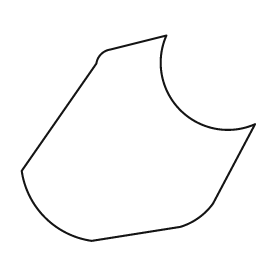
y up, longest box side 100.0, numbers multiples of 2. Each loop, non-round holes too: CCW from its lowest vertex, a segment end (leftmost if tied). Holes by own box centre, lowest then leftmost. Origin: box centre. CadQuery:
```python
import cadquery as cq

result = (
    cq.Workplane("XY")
    .moveTo(-20.0, -44.0)
    .lineTo(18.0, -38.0)
    .threePointArc((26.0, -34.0), (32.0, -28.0))
    .lineTo(50.0, 6.0)
    .threePointArc((18.0, 12.0), (12.0, 44.0))
    .lineTo(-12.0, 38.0)
    .threePointArc((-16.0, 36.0), (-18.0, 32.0))
    .lineTo(-50.0, -14.0)
    .threePointArc((-40.0, -34.0), (-20.0, -44.0))
    .close()
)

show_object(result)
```